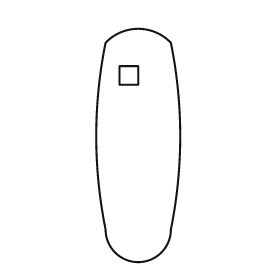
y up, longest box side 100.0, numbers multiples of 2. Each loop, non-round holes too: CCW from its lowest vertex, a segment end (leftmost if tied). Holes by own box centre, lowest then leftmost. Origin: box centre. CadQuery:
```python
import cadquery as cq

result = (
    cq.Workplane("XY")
    .moveTo(-14.0, -36.0)
    .threePointArc((0.0, -50.0), (14.0, -36.0))
    .threePointArc((18.0, 4.0), (14.0, 44.0))
    .threePointArc((0.0, 50.0), (-14.0, 44.0))
    .threePointArc((-18.0, 4.0), (-14.0, -36.0))
    .close()
    .moveTo(-8.0, 26.0)
    .lineTo(0.0, 26.0)
    .lineTo(0.0, 34.0)
    .lineTo(-8.0, 34.0)
    .close()
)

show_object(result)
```